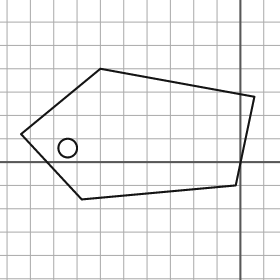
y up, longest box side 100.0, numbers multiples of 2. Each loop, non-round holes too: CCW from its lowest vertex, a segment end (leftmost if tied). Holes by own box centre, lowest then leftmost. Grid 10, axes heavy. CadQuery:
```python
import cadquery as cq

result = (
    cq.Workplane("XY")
    .moveTo(-68.0, -16.0)
    .lineTo(-2.0, -10.0)
    .lineTo(6.0, 28.0)
    .lineTo(-60.0, 40.0)
    .lineTo(-94.0, 12.0)
    .close()
    .moveTo(-74.0, 6.0)
    .circle(4.0)
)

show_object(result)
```